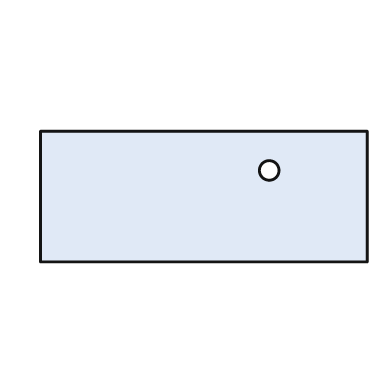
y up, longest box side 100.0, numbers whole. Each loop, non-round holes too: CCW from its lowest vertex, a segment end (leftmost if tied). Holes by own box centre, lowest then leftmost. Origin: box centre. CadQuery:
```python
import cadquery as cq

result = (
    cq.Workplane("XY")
    .moveTo(-50.0, -20.0)
    .lineTo(50.0, -20.0)
    .lineTo(50.0, 20.0)
    .lineTo(-50.0, 20.0)
    .close()
    .moveTo(20.0, 8.0)
    .circle(3.0)
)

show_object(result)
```